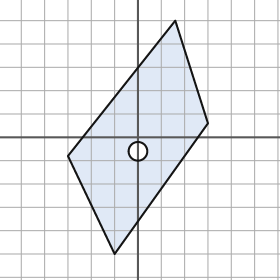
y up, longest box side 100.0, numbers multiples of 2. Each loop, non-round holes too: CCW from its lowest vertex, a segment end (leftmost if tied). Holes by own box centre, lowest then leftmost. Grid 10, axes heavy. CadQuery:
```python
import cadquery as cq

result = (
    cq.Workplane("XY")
    .moveTo(-10.0, -50.0)
    .lineTo(30.0, 6.0)
    .lineTo(16.0, 50.0)
    .lineTo(-30.0, -8.0)
    .close()
    .moveTo(0.0, -6.0)
    .circle(4.0)
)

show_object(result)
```